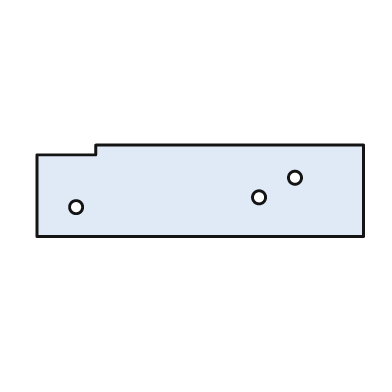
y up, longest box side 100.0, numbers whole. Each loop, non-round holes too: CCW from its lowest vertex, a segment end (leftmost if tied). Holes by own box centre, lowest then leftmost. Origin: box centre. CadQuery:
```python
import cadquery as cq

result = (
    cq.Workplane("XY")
    .moveTo(-50.0, -14.0)
    .lineTo(50.0, -14.0)
    .lineTo(50.0, 14.0)
    .lineTo(-32.0, 14.0)
    .lineTo(-32.0, 11.0)
    .lineTo(-50.0, 11.0)
    .close()
    .moveTo(-38.0, -5.0)
    .circle(2.0)
    .moveTo(18.0, -2.0)
    .circle(2.0)
    .moveTo(29.0, 4.0)
    .circle(2.0)
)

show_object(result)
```